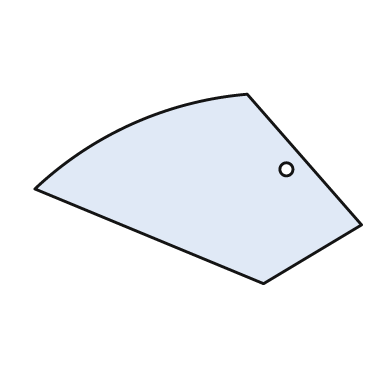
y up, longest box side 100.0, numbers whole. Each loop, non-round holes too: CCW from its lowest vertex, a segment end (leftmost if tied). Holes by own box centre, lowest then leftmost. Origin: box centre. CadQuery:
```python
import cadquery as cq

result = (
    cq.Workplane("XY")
    .moveTo(20.0, -29.0)
    .lineTo(50.0, -11.0)
    .lineTo(15.0, 29.0)
    .threePointArc((-20.0, 20.0), (-50.0, 0.0))
    .close()
    .moveTo(27.0, 6.0)
    .circle(2.0)
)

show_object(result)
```